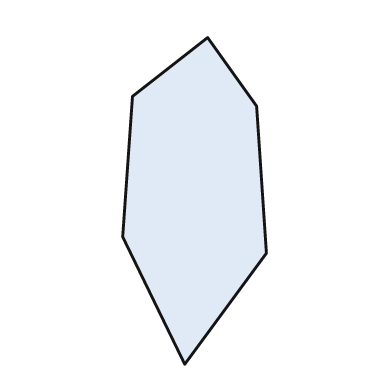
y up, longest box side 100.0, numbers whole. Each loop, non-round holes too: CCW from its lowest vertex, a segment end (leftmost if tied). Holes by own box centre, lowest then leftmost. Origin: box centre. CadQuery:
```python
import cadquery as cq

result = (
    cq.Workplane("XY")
    .moveTo(-3.0, -50.0)
    .lineTo(22.0, -16.0)
    .lineTo(19.0, 29.0)
    .lineTo(4.0, 50.0)
    .lineTo(-19.0, 32.0)
    .lineTo(-22.0, -11.0)
    .close()
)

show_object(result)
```